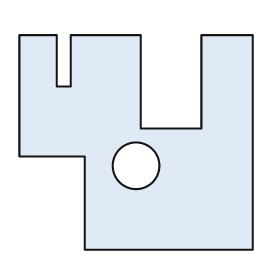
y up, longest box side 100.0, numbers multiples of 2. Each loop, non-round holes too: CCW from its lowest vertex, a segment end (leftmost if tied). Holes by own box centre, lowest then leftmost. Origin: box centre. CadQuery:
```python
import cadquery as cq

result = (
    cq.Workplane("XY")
    .moveTo(-22.0, -46.0)
    .lineTo(50.0, -46.0)
    .lineTo(50.0, 46.0)
    .lineTo(28.0, 46.0)
    .lineTo(28.0, 6.0)
    .lineTo(2.0, 6.0)
    .lineTo(2.0, 46.0)
    .lineTo(-28.0, 46.0)
    .lineTo(-28.0, 24.0)
    .lineTo(-34.0, 24.0)
    .lineTo(-34.0, 46.0)
    .lineTo(-50.0, 46.0)
    .lineTo(-50.0, -6.0)
    .lineTo(-22.0, -6.0)
    .close()
    .moveTo(0.0, -10.0)
    .circle(10.0)
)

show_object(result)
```